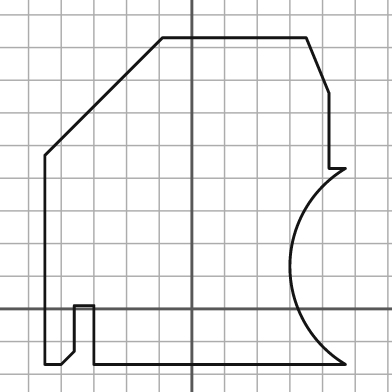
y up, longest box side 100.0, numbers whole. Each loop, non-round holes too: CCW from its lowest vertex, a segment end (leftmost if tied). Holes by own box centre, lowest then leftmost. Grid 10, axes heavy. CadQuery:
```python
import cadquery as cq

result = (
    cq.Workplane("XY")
    .moveTo(-45.0, -17.0)
    .lineTo(-40.0, -17.0)
    .lineTo(-36.0, -13.0)
    .lineTo(-36.0, 1.0)
    .lineTo(-30.0, 1.0)
    .lineTo(-30.0, -17.0)
    .lineTo(47.0, -17.0)
    .threePointArc((30.0, 13.0), (47.0, 43.0))
    .lineTo(42.0, 43.0)
    .lineTo(42.0, 66.0)
    .lineTo(35.0, 83.0)
    .lineTo(-9.0, 83.0)
    .lineTo(-45.0, 47.0)
    .close()
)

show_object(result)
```